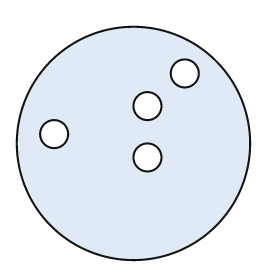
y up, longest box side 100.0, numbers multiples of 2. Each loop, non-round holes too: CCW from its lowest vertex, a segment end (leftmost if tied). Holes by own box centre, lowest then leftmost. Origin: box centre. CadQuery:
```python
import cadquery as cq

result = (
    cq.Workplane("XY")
    .moveTo(0.0, 0.0)
    .circle(50.0)
    .moveTo(6.0, -6.0)
    .circle(6.0)
    .moveTo(-34.0, 4.0)
    .circle(6.0)
    .moveTo(6.0, 16.0)
    .circle(6.0)
    .moveTo(22.0, 30.0)
    .circle(6.0)
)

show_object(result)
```